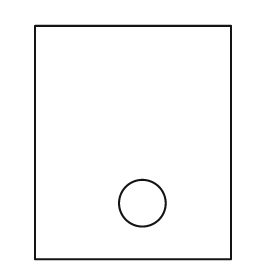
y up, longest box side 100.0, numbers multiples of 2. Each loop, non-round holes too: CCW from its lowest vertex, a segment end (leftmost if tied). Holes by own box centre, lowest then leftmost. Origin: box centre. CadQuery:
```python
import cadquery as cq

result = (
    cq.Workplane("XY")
    .moveTo(-42.0, -50.0)
    .lineTo(42.0, -50.0)
    .lineTo(42.0, 50.0)
    .lineTo(-42.0, 50.0)
    .close()
    .moveTo(4.0, -26.0)
    .circle(10.0)
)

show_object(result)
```